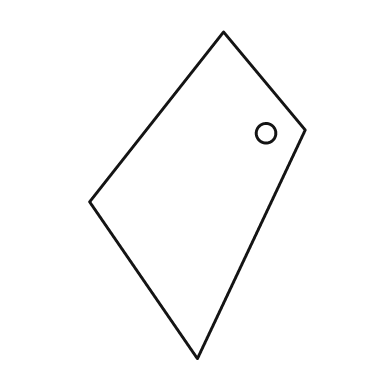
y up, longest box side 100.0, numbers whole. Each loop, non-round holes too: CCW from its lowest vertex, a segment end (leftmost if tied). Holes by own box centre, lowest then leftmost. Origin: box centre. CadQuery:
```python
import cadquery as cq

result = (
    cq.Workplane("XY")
    .moveTo(0.0, -50.0)
    .lineTo(33.0, 20.0)
    .lineTo(8.0, 50.0)
    .lineTo(-33.0, -2.0)
    .close()
    .moveTo(21.0, 19.0)
    .circle(3.0)
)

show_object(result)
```